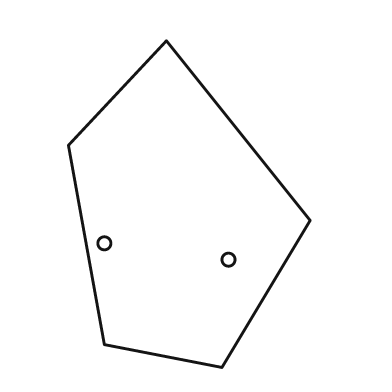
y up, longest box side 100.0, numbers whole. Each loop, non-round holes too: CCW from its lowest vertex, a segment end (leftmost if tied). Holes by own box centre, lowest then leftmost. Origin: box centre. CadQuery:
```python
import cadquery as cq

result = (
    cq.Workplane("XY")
    .moveTo(10.0, -50.0)
    .lineTo(37.0, -5.0)
    .lineTo(-7.0, 50.0)
    .lineTo(-37.0, 18.0)
    .lineTo(-26.0, -43.0)
    .close()
    .moveTo(12.0, -17.0)
    .circle(2.0)
    .moveTo(-26.0, -12.0)
    .circle(2.0)
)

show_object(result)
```